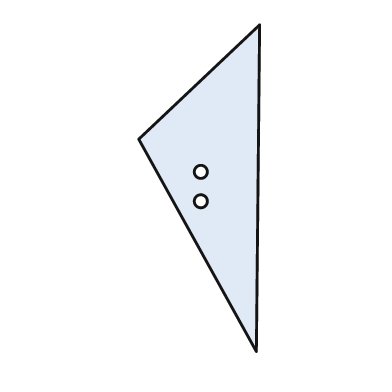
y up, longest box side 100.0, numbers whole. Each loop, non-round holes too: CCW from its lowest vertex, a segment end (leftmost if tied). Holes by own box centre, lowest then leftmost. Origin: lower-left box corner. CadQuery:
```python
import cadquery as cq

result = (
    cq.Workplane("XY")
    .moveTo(36.0, 0.0)
    .lineTo(37.0, 100.0)
    .lineTo(0.0, 65.0)
    .close()
    .moveTo(19.0, 46.0)
    .circle(2.0)
    .moveTo(19.0, 55.0)
    .circle(2.0)
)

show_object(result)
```